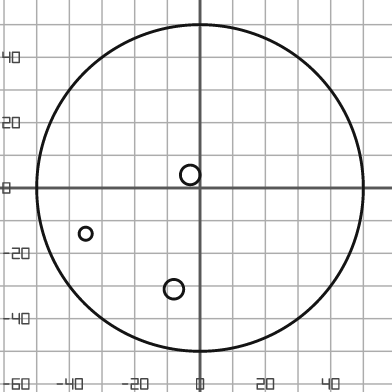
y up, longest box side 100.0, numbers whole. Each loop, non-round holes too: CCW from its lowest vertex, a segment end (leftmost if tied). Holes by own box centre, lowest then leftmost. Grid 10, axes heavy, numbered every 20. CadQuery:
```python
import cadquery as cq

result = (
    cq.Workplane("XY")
    .moveTo(0.0, 0.0)
    .circle(50.0)
    .moveTo(-8.0, -31.0)
    .circle(3.0)
    .moveTo(-35.0, -14.0)
    .circle(2.0)
    .moveTo(-3.0, 4.0)
    .circle(3.0)
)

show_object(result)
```